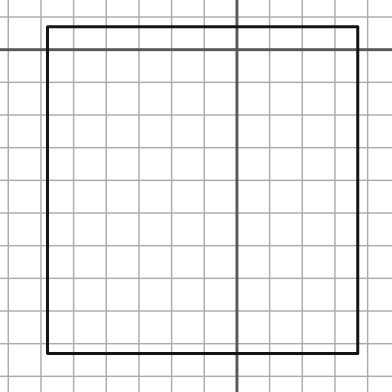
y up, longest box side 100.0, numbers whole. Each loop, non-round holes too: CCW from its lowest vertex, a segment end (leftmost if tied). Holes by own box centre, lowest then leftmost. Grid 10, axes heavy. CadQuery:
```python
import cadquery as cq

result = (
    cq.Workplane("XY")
    .moveTo(-58.0, -93.0)
    .lineTo(37.0, -93.0)
    .lineTo(37.0, 7.0)
    .lineTo(-58.0, 7.0)
    .close()
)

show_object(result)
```